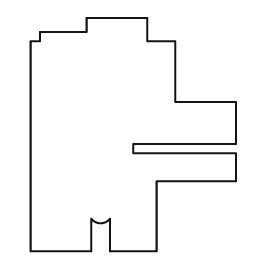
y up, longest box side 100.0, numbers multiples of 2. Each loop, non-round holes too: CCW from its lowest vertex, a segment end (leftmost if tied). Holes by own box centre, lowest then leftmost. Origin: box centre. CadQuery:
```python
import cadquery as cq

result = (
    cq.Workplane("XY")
    .moveTo(-44.0, -50.0)
    .lineTo(-18.0, -50.0)
    .lineTo(-18.0, -36.0)
    .threePointArc((-14.0, -38.0), (-10.0, -36.0))
    .lineTo(-10.0, -50.0)
    .lineTo(10.0, -50.0)
    .lineTo(10.0, -20.0)
    .lineTo(44.0, -20.0)
    .lineTo(44.0, -8.0)
    .lineTo(0.0, -8.0)
    .lineTo(0.0, -4.0)
    .lineTo(44.0, -4.0)
    .lineTo(44.0, 14.0)
    .lineTo(18.0, 14.0)
    .lineTo(18.0, 40.0)
    .lineTo(6.0, 40.0)
    .lineTo(6.0, 50.0)
    .lineTo(-20.0, 50.0)
    .lineTo(-20.0, 44.0)
    .lineTo(-40.0, 44.0)
    .lineTo(-40.0, 40.0)
    .lineTo(-44.0, 40.0)
    .close()
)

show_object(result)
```